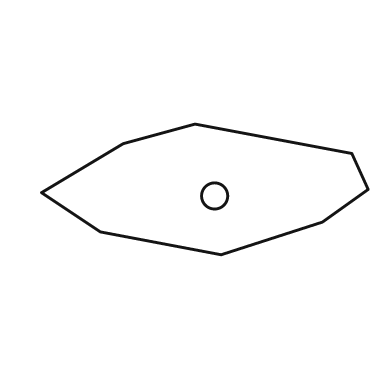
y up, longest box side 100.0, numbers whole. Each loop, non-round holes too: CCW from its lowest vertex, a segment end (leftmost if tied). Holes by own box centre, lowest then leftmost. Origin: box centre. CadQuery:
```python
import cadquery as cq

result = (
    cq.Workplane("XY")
    .moveTo(5.0, -20.0)
    .lineTo(36.0, -10.0)
    .lineTo(50.0, 0.0)
    .lineTo(45.0, 11.0)
    .lineTo(-3.0, 20.0)
    .lineTo(-25.0, 14.0)
    .lineTo(-50.0, -1.0)
    .lineTo(-32.0, -13.0)
    .close()
    .moveTo(3.0, -2.0)
    .circle(4.0)
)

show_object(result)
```